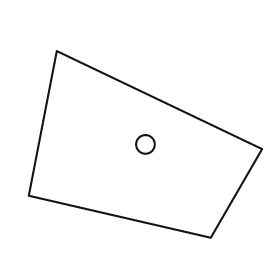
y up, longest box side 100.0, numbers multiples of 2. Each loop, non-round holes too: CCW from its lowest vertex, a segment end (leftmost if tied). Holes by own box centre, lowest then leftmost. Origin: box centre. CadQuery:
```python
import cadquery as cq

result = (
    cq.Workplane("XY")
    .moveTo(28.0, -40.0)
    .lineTo(50.0, -2.0)
    .lineTo(-38.0, 40.0)
    .lineTo(-50.0, -22.0)
    .close()
    .moveTo(0.0, 0.0)
    .circle(4.0)
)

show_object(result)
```